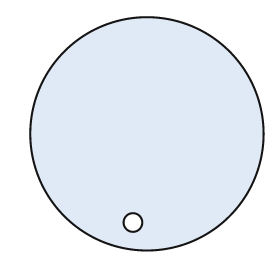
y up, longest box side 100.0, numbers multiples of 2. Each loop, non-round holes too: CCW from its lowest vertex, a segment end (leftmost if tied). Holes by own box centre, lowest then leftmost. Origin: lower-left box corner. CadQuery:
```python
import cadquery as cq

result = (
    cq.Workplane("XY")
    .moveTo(50.0, 50.0)
    .circle(50.0)
    .moveTo(44.0, 12.0)
    .circle(4.0)
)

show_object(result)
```